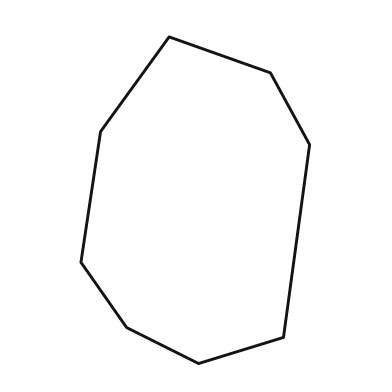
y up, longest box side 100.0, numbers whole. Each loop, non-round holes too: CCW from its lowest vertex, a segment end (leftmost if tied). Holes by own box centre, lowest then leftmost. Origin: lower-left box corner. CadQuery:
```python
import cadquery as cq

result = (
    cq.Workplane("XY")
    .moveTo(36.0, 0.0)
    .lineTo(62.0, 8.0)
    .lineTo(70.0, 67.0)
    .lineTo(58.0, 89.0)
    .lineTo(27.0, 100.0)
    .lineTo(6.0, 71.0)
    .lineTo(0.0, 31.0)
    .lineTo(14.0, 11.0)
    .close()
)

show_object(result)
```